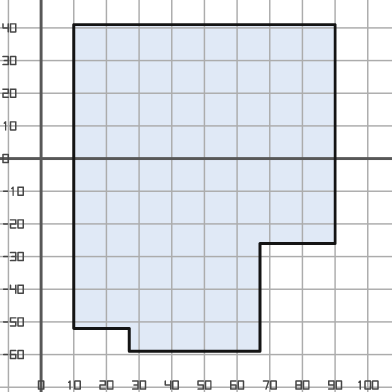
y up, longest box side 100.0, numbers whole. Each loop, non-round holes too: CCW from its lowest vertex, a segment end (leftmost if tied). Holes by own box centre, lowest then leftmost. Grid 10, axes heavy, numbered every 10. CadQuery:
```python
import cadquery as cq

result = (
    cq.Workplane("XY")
    .moveTo(27.0, -59.0)
    .lineTo(67.0, -59.0)
    .lineTo(67.0, -26.0)
    .lineTo(90.0, -26.0)
    .lineTo(90.0, 41.0)
    .lineTo(10.0, 41.0)
    .lineTo(10.0, -52.0)
    .lineTo(27.0, -52.0)
    .close()
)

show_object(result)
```